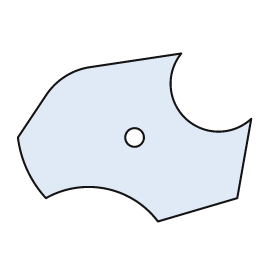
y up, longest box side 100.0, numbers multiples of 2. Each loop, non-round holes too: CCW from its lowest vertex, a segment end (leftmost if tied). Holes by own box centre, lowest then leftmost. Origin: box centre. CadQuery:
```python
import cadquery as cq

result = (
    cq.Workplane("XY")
    .moveTo(10.0, -36.0)
    .lineTo(44.0, -26.0)
    .lineTo(50.0, 8.0)
    .threePointArc((22.0, 8.0), (20.0, 36.0))
    .lineTo(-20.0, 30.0)
    .threePointArc((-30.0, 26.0), (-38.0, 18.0))
    .lineTo(-50.0, 0.0)
    .threePointArc((-46.0, -14.0), (-38.0, -26.0))
    .threePointArc((-12.0, -22.0), (10.0, -36.0))
    .close()
    .moveTo(0.0, 0.0)
    .circle(4.0)
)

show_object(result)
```